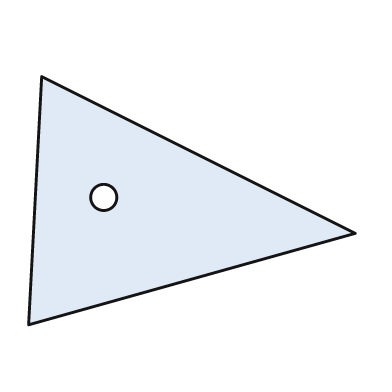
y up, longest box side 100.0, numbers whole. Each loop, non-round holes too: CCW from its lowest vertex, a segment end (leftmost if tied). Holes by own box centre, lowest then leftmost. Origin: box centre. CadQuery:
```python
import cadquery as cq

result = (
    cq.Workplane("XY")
    .moveTo(-50.0, -38.0)
    .lineTo(50.0, -10.0)
    .lineTo(-46.0, 38.0)
    .close()
    .moveTo(-27.0, 1.0)
    .circle(4.0)
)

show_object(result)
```